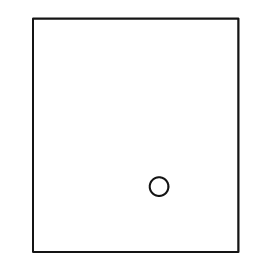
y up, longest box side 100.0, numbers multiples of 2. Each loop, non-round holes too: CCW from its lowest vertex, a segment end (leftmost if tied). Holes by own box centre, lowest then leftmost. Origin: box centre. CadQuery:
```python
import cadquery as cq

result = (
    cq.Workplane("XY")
    .moveTo(-44.0, -50.0)
    .lineTo(44.0, -50.0)
    .lineTo(44.0, 50.0)
    .lineTo(-44.0, 50.0)
    .close()
    .moveTo(10.0, -22.0)
    .circle(4.0)
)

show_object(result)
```